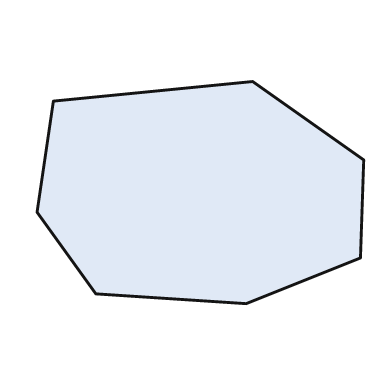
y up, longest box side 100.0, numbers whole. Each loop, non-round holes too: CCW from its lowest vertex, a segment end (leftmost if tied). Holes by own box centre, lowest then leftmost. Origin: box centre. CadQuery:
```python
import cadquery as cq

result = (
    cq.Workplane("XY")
    .moveTo(14.0, -34.0)
    .lineTo(49.0, -20.0)
    .lineTo(50.0, 10.0)
    .lineTo(16.0, 34.0)
    .lineTo(-45.0, 28.0)
    .lineTo(-50.0, -6.0)
    .lineTo(-32.0, -31.0)
    .close()
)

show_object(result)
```